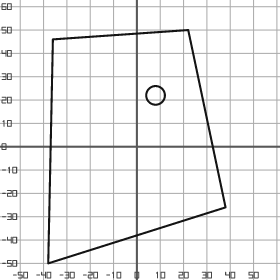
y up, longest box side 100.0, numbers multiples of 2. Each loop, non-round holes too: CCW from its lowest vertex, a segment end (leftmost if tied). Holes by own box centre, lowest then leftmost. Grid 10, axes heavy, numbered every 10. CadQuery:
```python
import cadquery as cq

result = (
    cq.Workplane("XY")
    .moveTo(-38.0, -50.0)
    .lineTo(38.0, -26.0)
    .lineTo(22.0, 50.0)
    .lineTo(-36.0, 46.0)
    .close()
    .moveTo(8.0, 22.0)
    .circle(4.0)
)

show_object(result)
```